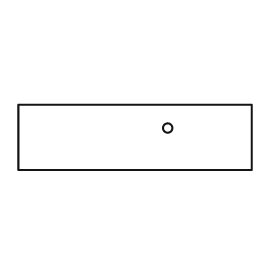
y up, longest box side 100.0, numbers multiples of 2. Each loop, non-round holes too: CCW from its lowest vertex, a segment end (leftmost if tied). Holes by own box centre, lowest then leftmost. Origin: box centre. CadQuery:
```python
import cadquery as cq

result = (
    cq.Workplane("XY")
    .moveTo(-50.0, -14.0)
    .lineTo(50.0, -14.0)
    .lineTo(50.0, 14.0)
    .lineTo(-50.0, 14.0)
    .close()
    .moveTo(14.0, 4.0)
    .circle(2.0)
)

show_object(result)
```